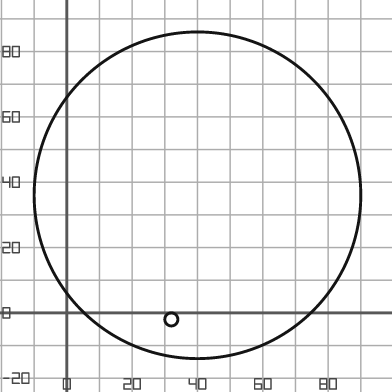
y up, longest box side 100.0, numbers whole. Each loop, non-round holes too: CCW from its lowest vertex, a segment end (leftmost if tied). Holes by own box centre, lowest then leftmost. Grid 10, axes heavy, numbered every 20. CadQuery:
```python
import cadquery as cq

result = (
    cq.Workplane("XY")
    .moveTo(40.0, 36.0)
    .circle(50.0)
    .moveTo(32.0, -2.0)
    .circle(2.0)
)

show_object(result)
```